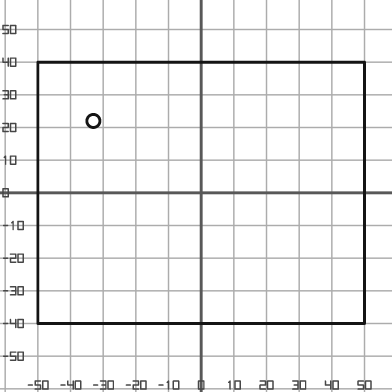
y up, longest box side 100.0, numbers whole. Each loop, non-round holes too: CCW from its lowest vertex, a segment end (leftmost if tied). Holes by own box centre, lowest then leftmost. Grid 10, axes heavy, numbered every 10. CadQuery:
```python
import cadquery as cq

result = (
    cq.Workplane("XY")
    .moveTo(-50.0, -40.0)
    .lineTo(50.0, -40.0)
    .lineTo(50.0, 40.0)
    .lineTo(-50.0, 40.0)
    .close()
    .moveTo(-33.0, 22.0)
    .circle(2.0)
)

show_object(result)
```